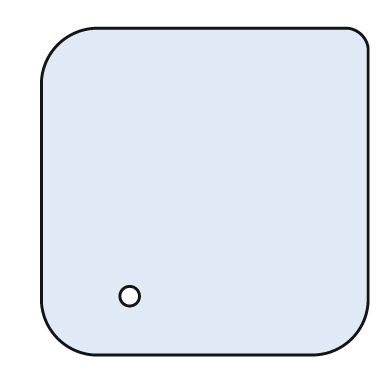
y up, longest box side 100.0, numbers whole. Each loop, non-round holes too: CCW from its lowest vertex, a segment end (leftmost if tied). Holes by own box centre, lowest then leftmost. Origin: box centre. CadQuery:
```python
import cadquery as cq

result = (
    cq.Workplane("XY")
    .moveTo(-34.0, -50.0)
    .lineTo(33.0, -50.0)
    .threePointArc((45.0, -45.0), (50.0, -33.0))
    .lineTo(50.0, 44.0)
    .threePointArc((48.0, 48.0), (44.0, 50.0))
    .lineTo(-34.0, 50.0)
    .threePointArc((-45.0, 45.0), (-50.0, 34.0))
    .lineTo(-50.0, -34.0)
    .threePointArc((-45.0, -45.0), (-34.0, -50.0))
    .close()
    .moveTo(-23.0, -32.0)
    .circle(3.0)
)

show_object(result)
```